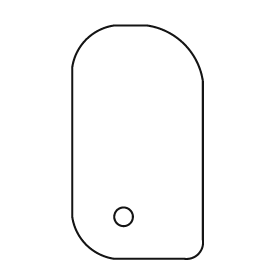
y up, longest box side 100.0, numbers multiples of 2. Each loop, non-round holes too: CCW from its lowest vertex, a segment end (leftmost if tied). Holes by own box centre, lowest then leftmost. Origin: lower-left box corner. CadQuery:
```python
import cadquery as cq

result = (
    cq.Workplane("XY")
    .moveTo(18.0, 0.0)
    .lineTo(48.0, 0.0)
    .threePointArc((54.0, 2.0), (56.0, 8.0))
    .lineTo(56.0, 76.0)
    .threePointArc((48.0, 92.0), (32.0, 100.0))
    .lineTo(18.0, 100.0)
    .threePointArc((6.0, 94.0), (0.0, 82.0))
    .lineTo(0.0, 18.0)
    .threePointArc((6.0, 6.0), (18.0, 0.0))
    .close()
    .moveTo(22.0, 18.0)
    .circle(4.0)
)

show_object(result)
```